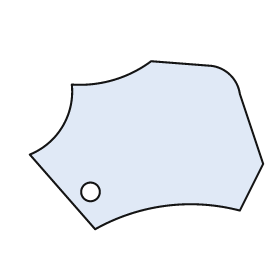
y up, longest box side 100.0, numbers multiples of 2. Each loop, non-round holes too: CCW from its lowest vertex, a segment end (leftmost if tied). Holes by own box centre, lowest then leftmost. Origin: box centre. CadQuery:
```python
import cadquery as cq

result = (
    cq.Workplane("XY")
    .moveTo(-22.0, -36.0)
    .threePointArc((8.0, -26.0), (40.0, -28.0))
    .lineTo(50.0, -8.0)
    .lineTo(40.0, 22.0)
    .threePointArc((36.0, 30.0), (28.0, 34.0))
    .lineTo(2.0, 36.0)
    .threePointArc((-14.0, 28.0), (-32.0, 26.0))
    .threePointArc((-36.0, 8.0), (-50.0, -4.0))
    .close()
    .moveTo(-24.0, -20.0)
    .circle(4.0)
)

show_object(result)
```